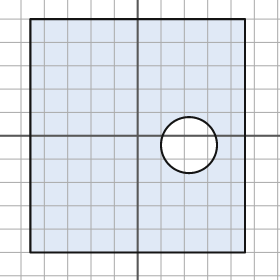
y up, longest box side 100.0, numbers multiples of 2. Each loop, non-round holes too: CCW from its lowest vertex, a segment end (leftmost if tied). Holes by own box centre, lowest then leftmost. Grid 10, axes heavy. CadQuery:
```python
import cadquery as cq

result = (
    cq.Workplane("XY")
    .moveTo(-46.0, -50.0)
    .lineTo(46.0, -50.0)
    .lineTo(46.0, 50.0)
    .lineTo(-46.0, 50.0)
    .close()
    .moveTo(22.0, -4.0)
    .circle(12.0)
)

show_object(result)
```